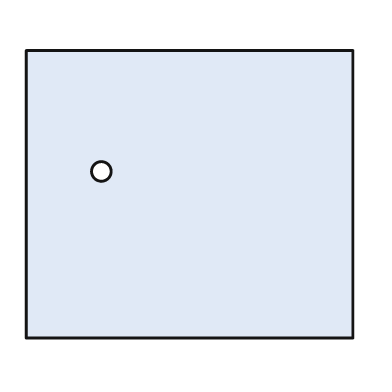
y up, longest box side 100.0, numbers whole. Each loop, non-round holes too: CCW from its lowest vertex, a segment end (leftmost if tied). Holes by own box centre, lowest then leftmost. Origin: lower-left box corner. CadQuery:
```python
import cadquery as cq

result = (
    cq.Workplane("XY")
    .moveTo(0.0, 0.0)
    .lineTo(100.0, 0.0)
    .lineTo(100.0, 88.0)
    .lineTo(0.0, 88.0)
    .close()
    .moveTo(23.0, 51.0)
    .circle(3.0)
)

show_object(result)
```